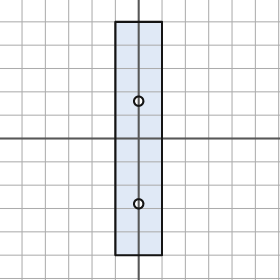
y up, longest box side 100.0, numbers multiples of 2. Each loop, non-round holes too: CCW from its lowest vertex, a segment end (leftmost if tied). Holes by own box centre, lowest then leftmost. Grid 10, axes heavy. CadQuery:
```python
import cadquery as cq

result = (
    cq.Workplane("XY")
    .moveTo(-10.0, -50.0)
    .lineTo(10.0, -50.0)
    .lineTo(10.0, 50.0)
    .lineTo(-10.0, 50.0)
    .close()
    .moveTo(0.0, -28.0)
    .circle(2.0)
    .moveTo(0.0, 16.0)
    .circle(2.0)
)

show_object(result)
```